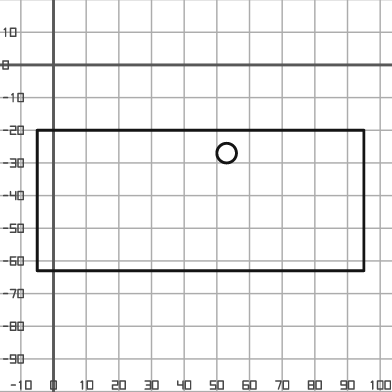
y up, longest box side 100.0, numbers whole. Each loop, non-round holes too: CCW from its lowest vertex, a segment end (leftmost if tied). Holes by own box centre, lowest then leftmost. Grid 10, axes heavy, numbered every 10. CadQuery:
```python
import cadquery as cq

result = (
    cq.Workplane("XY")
    .moveTo(-5.0, -63.0)
    .lineTo(95.0, -63.0)
    .lineTo(95.0, -20.0)
    .lineTo(-5.0, -20.0)
    .close()
    .moveTo(53.0, -27.0)
    .circle(3.0)
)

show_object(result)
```